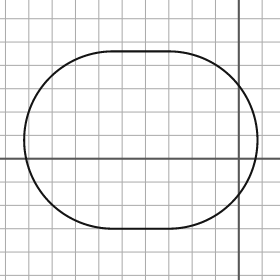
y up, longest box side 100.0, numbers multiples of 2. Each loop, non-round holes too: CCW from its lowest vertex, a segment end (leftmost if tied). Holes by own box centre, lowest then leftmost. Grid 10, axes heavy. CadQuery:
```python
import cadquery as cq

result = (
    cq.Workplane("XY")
    .moveTo(-54.0, -30.0)
    .lineTo(-30.0, -30.0)
    .threePointArc((8.0, 8.0), (-30.0, 46.0))
    .lineTo(-54.0, 46.0)
    .threePointArc((-92.0, 8.0), (-54.0, -30.0))
    .close()
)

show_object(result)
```